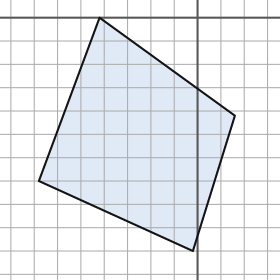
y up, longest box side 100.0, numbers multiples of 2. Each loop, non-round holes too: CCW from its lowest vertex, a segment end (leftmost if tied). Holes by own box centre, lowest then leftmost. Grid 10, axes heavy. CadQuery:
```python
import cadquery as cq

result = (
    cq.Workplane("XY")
    .moveTo(-2.0, -100.0)
    .lineTo(16.0, -42.0)
    .lineTo(-42.0, 0.0)
    .lineTo(-68.0, -70.0)
    .close()
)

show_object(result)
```